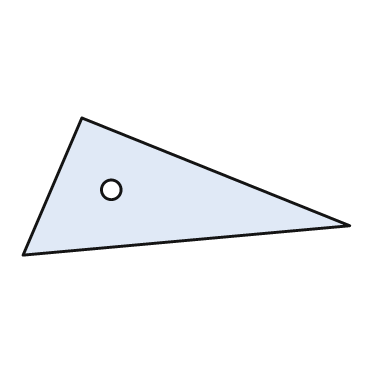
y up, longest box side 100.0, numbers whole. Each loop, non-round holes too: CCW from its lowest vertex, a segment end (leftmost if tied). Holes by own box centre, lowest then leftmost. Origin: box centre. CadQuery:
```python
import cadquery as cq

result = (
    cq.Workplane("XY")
    .moveTo(-50.0, -21.0)
    .lineTo(50.0, -12.0)
    .lineTo(-32.0, 21.0)
    .close()
    .moveTo(-23.0, -1.0)
    .circle(3.0)
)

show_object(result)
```